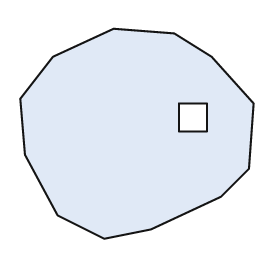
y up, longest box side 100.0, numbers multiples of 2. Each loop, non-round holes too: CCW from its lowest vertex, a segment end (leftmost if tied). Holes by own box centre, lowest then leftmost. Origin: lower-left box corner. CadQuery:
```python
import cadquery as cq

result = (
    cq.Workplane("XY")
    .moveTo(36.0, 0.0)
    .lineTo(56.0, 4.0)
    .lineTo(86.0, 18.0)
    .lineTo(98.0, 30.0)
    .lineTo(100.0, 58.0)
    .lineTo(82.0, 78.0)
    .lineTo(66.0, 88.0)
    .lineTo(40.0, 90.0)
    .lineTo(14.0, 78.0)
    .lineTo(0.0, 60.0)
    .lineTo(2.0, 36.0)
    .lineTo(16.0, 10.0)
    .close()
    .moveTo(68.0, 46.0)
    .lineTo(80.0, 46.0)
    .lineTo(80.0, 58.0)
    .lineTo(68.0, 58.0)
    .close()
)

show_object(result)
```